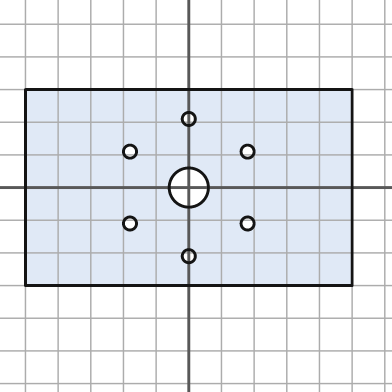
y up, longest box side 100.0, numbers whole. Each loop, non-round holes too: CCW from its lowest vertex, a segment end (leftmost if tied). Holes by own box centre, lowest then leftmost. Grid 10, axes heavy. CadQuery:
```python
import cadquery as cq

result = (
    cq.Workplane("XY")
    .moveTo(-50.0, -30.0)
    .lineTo(50.0, -30.0)
    .lineTo(50.0, 30.0)
    .lineTo(-50.0, 30.0)
    .close()
    .moveTo(0.0, -21.0)
    .circle(2.0)
    .moveTo(-18.0, -11.0)
    .circle(2.0)
    .moveTo(18.0, -11.0)
    .circle(2.0)
    .moveTo(0.0, 0.0)
    .circle(6.0)
    .moveTo(-18.0, 11.0)
    .circle(2.0)
    .moveTo(18.0, 11.0)
    .circle(2.0)
    .moveTo(0.0, 21.0)
    .circle(2.0)
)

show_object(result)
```